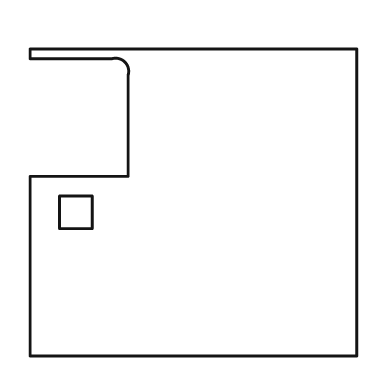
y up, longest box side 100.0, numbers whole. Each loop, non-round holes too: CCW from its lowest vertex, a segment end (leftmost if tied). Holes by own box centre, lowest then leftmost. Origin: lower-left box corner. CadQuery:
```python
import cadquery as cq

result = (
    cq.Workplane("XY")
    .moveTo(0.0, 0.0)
    .lineTo(100.0, 0.0)
    .lineTo(100.0, 94.0)
    .lineTo(0.0, 94.0)
    .lineTo(0.0, 91.0)
    .lineTo(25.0, 91.0)
    .threePointArc((29.0, 90.0), (30.0, 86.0))
    .lineTo(30.0, 55.0)
    .lineTo(0.0, 55.0)
    .close()
    .moveTo(9.0, 39.0)
    .lineTo(19.0, 39.0)
    .lineTo(19.0, 49.0)
    .lineTo(9.0, 49.0)
    .close()
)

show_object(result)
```